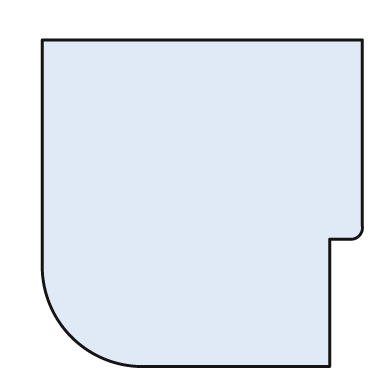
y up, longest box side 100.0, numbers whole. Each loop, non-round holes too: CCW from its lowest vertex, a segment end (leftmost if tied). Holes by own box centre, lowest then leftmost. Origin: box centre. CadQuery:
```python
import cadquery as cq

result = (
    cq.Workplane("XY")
    .moveTo(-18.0, -50.0)
    .lineTo(39.0, -50.0)
    .lineTo(39.0, -11.0)
    .lineTo(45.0, -11.0)
    .threePointArc((48.0, -10.0), (49.0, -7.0))
    .lineTo(49.0, 50.0)
    .lineTo(-49.0, 50.0)
    .lineTo(-49.0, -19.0)
    .threePointArc((-40.0, -41.0), (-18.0, -50.0))
    .close()
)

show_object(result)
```